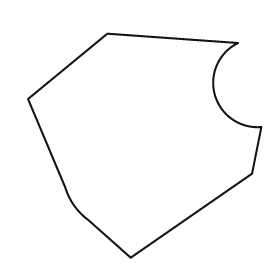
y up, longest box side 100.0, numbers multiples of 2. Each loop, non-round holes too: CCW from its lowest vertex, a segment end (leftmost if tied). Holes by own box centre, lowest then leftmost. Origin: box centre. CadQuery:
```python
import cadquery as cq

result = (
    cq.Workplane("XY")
    .moveTo(-6.0, -48.0)
    .lineTo(46.0, -12.0)
    .lineTo(50.0, 8.0)
    .threePointArc((30.0, 22.0), (40.0, 44.0))
    .lineTo(-16.0, 48.0)
    .lineTo(-50.0, 20.0)
    .lineTo(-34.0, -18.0)
    .threePointArc((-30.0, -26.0), (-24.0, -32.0))
    .close()
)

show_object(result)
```